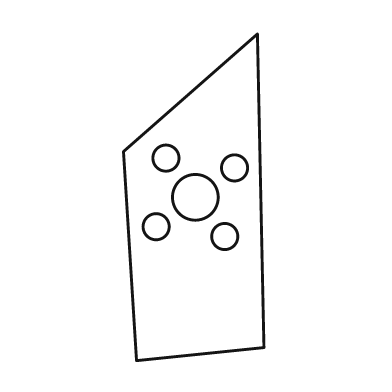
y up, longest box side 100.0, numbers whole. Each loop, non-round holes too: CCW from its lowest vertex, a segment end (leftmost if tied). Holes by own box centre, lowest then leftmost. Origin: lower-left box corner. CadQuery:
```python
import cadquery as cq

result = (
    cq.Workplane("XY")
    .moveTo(4.0, 0.0)
    .lineTo(43.0, 4.0)
    .lineTo(41.0, 100.0)
    .lineTo(0.0, 64.0)
    .close()
    .moveTo(31.0, 38.0)
    .circle(4.0)
    .moveTo(10.0, 41.0)
    .circle(4.0)
    .moveTo(22.0, 50.0)
    .circle(7.0)
    .moveTo(34.0, 59.0)
    .circle(4.0)
    .moveTo(13.0, 62.0)
    .circle(4.0)
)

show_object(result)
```